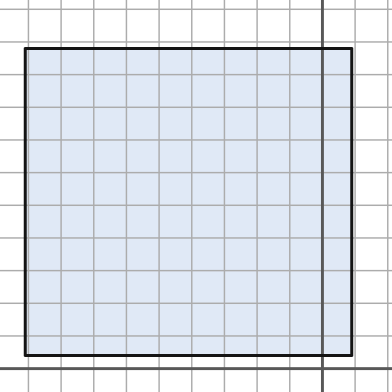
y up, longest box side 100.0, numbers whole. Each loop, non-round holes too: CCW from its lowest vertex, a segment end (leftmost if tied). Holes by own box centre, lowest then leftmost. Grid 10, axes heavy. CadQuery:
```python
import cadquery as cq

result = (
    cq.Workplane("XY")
    .moveTo(-91.0, 4.0)
    .lineTo(9.0, 4.0)
    .lineTo(9.0, 98.0)
    .lineTo(-91.0, 98.0)
    .close()
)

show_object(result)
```